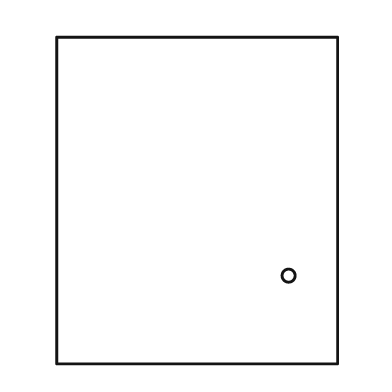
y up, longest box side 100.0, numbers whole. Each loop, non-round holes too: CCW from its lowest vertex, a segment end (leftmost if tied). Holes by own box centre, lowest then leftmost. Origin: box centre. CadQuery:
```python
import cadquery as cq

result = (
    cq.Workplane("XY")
    .moveTo(-43.0, -50.0)
    .lineTo(43.0, -50.0)
    .lineTo(43.0, 50.0)
    .lineTo(-43.0, 50.0)
    .close()
    .moveTo(28.0, -23.0)
    .circle(2.0)
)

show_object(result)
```